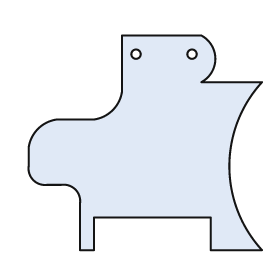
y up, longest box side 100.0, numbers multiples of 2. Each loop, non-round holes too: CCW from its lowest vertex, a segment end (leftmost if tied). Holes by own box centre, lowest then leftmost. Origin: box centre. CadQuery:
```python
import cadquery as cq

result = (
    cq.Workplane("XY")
    .moveTo(-28.0, -46.0)
    .lineTo(-22.0, -46.0)
    .lineTo(-22.0, -32.0)
    .lineTo(28.0, -32.0)
    .lineTo(28.0, -46.0)
    .lineTo(50.0, -46.0)
    .threePointArc((36.0, -10.0), (50.0, 26.0))
    .lineTo(24.0, 26.0)
    .threePointArc((30.0, 36.0), (24.0, 46.0))
    .lineTo(-10.0, 46.0)
    .lineTo(-10.0, 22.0)
    .threePointArc((-14.0, 14.0), (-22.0, 10.0))
    .lineTo(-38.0, 10.0)
    .threePointArc((-46.0, 6.0), (-50.0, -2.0))
    .lineTo(-50.0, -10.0)
    .threePointArc((-48.0, -16.0), (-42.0, -18.0))
    .lineTo(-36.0, -18.0)
    .threePointArc((-30.0, -20.0), (-28.0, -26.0))
    .close()
    .moveTo(-4.0, 38.0)
    .circle(2.0)
    .moveTo(20.0, 38.0)
    .circle(2.0)
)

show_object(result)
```